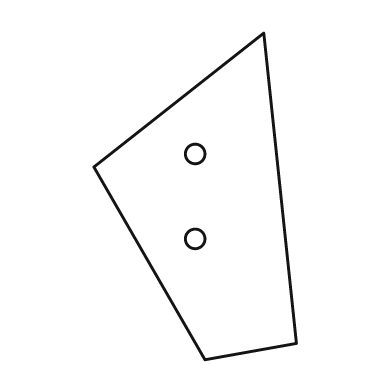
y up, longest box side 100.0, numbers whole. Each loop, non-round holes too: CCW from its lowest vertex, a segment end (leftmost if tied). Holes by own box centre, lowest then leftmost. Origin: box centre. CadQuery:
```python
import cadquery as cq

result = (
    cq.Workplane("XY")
    .moveTo(3.0, -50.0)
    .lineTo(31.0, -45.0)
    .lineTo(21.0, 50.0)
    .lineTo(-31.0, 9.0)
    .close()
    .moveTo(0.0, -13.0)
    .circle(3.0)
    .moveTo(0.0, 13.0)
    .circle(3.0)
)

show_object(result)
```